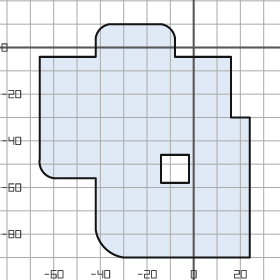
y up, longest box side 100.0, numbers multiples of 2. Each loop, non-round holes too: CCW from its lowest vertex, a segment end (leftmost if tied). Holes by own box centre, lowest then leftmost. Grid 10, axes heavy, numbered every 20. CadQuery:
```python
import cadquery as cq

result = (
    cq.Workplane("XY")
    .moveTo(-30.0, -90.0)
    .lineTo(24.0, -90.0)
    .lineTo(24.0, -30.0)
    .lineTo(16.0, -30.0)
    .lineTo(16.0, -4.0)
    .lineTo(-8.0, -4.0)
    .lineTo(-8.0, 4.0)
    .threePointArc((-10.0, 8.0), (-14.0, 10.0))
    .lineTo(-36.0, 10.0)
    .threePointArc((-40.0, 8.0), (-42.0, 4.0))
    .lineTo(-42.0, -4.0)
    .lineTo(-66.0, -4.0)
    .lineTo(-66.0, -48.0)
    .threePointArc((-64.0, -54.0), (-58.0, -56.0))
    .lineTo(-42.0, -56.0)
    .lineTo(-42.0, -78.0)
    .threePointArc((-38.0, -86.0), (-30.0, -90.0))
    .close()
    .moveTo(-14.0, -58.0)
    .lineTo(-2.0, -58.0)
    .lineTo(-2.0, -46.0)
    .lineTo(-14.0, -46.0)
    .close()
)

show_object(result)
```